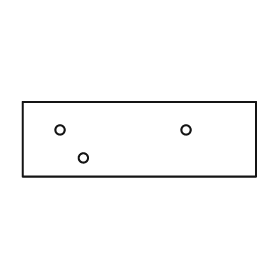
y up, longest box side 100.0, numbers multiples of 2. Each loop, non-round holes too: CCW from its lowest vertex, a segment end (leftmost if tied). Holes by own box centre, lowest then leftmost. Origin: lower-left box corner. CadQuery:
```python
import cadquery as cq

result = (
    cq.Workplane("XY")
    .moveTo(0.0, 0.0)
    .lineTo(100.0, 0.0)
    .lineTo(100.0, 32.0)
    .lineTo(0.0, 32.0)
    .close()
    .moveTo(26.0, 8.0)
    .circle(2.0)
    .moveTo(16.0, 20.0)
    .circle(2.0)
    .moveTo(70.0, 20.0)
    .circle(2.0)
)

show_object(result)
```